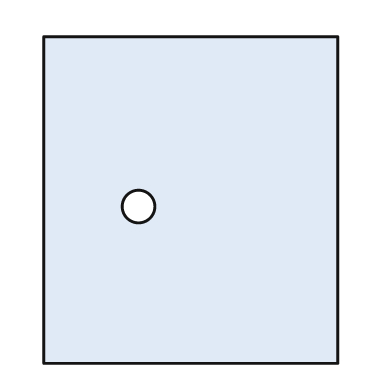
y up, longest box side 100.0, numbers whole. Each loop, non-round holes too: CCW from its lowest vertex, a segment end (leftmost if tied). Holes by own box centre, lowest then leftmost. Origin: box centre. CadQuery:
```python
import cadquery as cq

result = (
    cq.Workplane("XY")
    .moveTo(-45.0, -50.0)
    .lineTo(45.0, -50.0)
    .lineTo(45.0, 50.0)
    .lineTo(-45.0, 50.0)
    .close()
    .moveTo(-16.0, -2.0)
    .circle(5.0)
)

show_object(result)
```